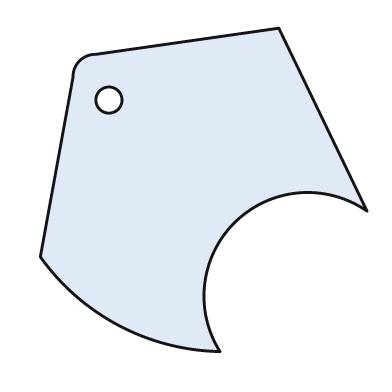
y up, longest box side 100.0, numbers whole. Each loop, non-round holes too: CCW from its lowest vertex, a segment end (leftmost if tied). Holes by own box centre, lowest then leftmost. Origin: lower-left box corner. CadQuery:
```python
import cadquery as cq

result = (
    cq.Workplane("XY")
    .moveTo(55.0, 0.0)
    .threePointArc((60.0, 40.0), (100.0, 43.0))
    .lineTo(73.0, 99.0)
    .lineTo(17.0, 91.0)
    .threePointArc((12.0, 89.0), (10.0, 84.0))
    .lineTo(0.0, 29.0)
    .threePointArc((24.0, 8.0), (55.0, 0.0))
    .close()
    .moveTo(21.0, 77.0)
    .circle(4.0)
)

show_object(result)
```